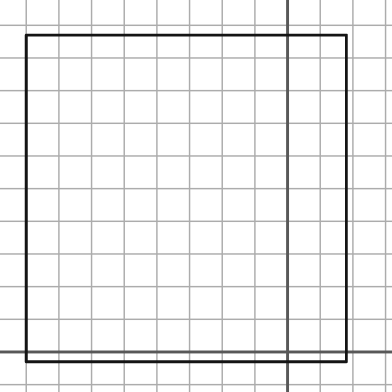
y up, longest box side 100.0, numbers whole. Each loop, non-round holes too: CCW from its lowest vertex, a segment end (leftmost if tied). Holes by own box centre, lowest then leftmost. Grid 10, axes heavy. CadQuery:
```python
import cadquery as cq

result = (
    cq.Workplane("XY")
    .moveTo(-80.0, -3.0)
    .lineTo(18.0, -3.0)
    .lineTo(18.0, 97.0)
    .lineTo(-80.0, 97.0)
    .close()
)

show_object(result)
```